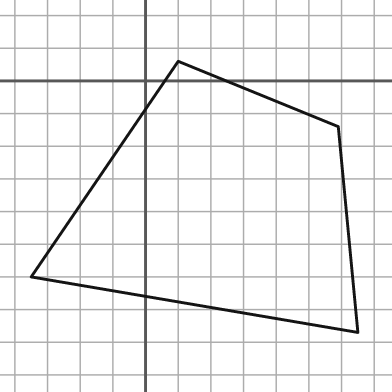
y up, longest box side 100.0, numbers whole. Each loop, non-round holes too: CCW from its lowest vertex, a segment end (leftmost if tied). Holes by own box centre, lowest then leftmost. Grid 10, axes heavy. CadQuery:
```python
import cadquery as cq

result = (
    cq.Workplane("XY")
    .moveTo(65.0, -77.0)
    .lineTo(59.0, -14.0)
    .lineTo(10.0, 6.0)
    .lineTo(-35.0, -60.0)
    .close()
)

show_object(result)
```